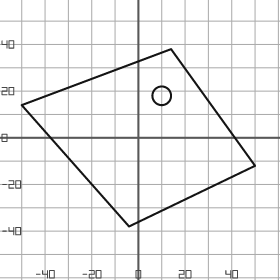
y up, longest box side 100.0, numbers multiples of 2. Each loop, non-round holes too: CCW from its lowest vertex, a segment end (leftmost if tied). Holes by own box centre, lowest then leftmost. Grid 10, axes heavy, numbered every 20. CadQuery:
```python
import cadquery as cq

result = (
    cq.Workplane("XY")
    .moveTo(-4.0, -38.0)
    .lineTo(50.0, -12.0)
    .lineTo(14.0, 38.0)
    .lineTo(-50.0, 14.0)
    .close()
    .moveTo(10.0, 18.0)
    .circle(4.0)
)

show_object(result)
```